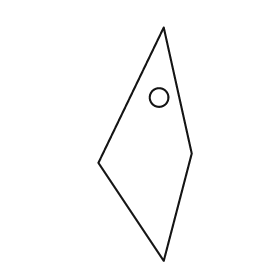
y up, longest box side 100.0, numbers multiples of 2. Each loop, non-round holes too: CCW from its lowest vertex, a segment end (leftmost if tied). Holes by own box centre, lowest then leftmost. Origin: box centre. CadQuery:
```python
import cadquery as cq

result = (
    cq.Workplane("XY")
    .moveTo(8.0, -50.0)
    .lineTo(20.0, -4.0)
    .lineTo(8.0, 50.0)
    .lineTo(-20.0, -8.0)
    .close()
    .moveTo(6.0, 20.0)
    .circle(4.0)
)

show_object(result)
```